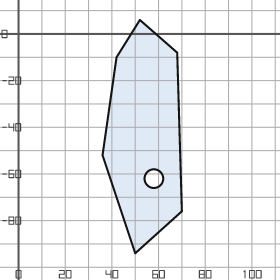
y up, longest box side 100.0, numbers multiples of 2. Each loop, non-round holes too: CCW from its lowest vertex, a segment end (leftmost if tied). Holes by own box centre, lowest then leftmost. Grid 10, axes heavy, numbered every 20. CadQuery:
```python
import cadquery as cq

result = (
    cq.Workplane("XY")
    .moveTo(50.0, -94.0)
    .lineTo(70.0, -76.0)
    .lineTo(68.0, -8.0)
    .lineTo(52.0, 6.0)
    .lineTo(42.0, -10.0)
    .lineTo(36.0, -52.0)
    .close()
    .moveTo(58.0, -62.0)
    .circle(4.0)
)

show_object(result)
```